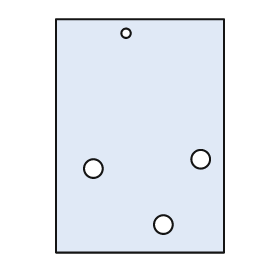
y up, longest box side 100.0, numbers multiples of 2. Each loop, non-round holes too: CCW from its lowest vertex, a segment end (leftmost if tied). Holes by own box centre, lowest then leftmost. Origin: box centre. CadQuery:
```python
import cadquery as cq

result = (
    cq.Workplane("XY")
    .moveTo(-36.0, -50.0)
    .lineTo(36.0, -50.0)
    .lineTo(36.0, 50.0)
    .lineTo(-36.0, 50.0)
    .close()
    .moveTo(10.0, -38.0)
    .circle(4.0)
    .moveTo(-20.0, -14.0)
    .circle(4.0)
    .moveTo(26.0, -10.0)
    .circle(4.0)
    .moveTo(-6.0, 44.0)
    .circle(2.0)
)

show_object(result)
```